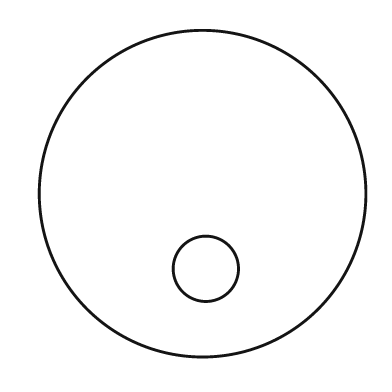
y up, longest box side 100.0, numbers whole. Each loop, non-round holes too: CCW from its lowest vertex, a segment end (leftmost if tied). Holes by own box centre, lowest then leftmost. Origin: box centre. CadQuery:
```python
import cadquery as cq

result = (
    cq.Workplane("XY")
    .moveTo(0.0, 0.0)
    .circle(50.0)
    .moveTo(1.0, -23.0)
    .circle(10.0)
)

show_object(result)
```